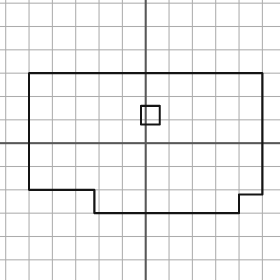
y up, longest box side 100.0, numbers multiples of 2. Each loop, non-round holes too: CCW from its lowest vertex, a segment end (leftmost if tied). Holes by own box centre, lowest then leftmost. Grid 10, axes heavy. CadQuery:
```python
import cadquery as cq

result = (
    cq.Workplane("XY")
    .moveTo(-22.0, -30.0)
    .lineTo(40.0, -30.0)
    .lineTo(40.0, -22.0)
    .lineTo(50.0, -22.0)
    .lineTo(50.0, 30.0)
    .lineTo(-50.0, 30.0)
    .lineTo(-50.0, -20.0)
    .lineTo(-22.0, -20.0)
    .close()
    .moveTo(-2.0, 8.0)
    .lineTo(6.0, 8.0)
    .lineTo(6.0, 16.0)
    .lineTo(-2.0, 16.0)
    .close()
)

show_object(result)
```